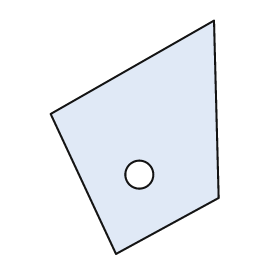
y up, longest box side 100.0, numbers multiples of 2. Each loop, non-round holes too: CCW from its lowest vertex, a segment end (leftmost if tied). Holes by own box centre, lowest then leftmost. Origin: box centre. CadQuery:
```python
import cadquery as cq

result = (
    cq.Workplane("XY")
    .moveTo(-8.0, -50.0)
    .lineTo(36.0, -26.0)
    .lineTo(34.0, 50.0)
    .lineTo(-36.0, 10.0)
    .close()
    .moveTo(2.0, -16.0)
    .circle(6.0)
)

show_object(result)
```